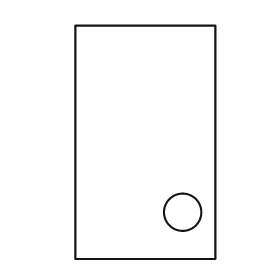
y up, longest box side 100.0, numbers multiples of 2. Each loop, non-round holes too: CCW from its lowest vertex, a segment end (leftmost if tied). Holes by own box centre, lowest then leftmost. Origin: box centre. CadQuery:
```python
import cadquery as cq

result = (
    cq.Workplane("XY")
    .moveTo(-30.0, -50.0)
    .lineTo(30.0, -50.0)
    .lineTo(30.0, 50.0)
    .lineTo(-30.0, 50.0)
    .close()
    .moveTo(16.0, -30.0)
    .circle(8.0)
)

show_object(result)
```